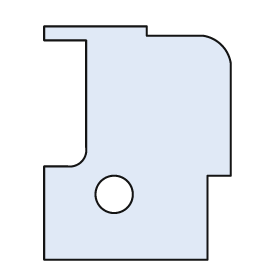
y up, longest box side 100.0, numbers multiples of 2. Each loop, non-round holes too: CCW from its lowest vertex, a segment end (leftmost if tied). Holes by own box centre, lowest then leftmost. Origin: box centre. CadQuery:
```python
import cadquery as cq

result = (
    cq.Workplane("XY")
    .moveTo(-40.0, -50.0)
    .lineTo(30.0, -50.0)
    .lineTo(30.0, -14.0)
    .lineTo(40.0, -14.0)
    .lineTo(40.0, 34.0)
    .threePointArc((36.0, 42.0), (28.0, 46.0))
    .lineTo(4.0, 46.0)
    .lineTo(4.0, 50.0)
    .lineTo(-40.0, 50.0)
    .lineTo(-40.0, 44.0)
    .lineTo(-22.0, 44.0)
    .lineTo(-22.0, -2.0)
    .threePointArc((-24.0, -8.0), (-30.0, -10.0))
    .lineTo(-40.0, -10.0)
    .close()
    .moveTo(-10.0, -22.0)
    .circle(8.0)
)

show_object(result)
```